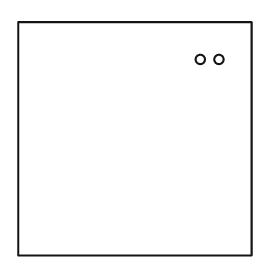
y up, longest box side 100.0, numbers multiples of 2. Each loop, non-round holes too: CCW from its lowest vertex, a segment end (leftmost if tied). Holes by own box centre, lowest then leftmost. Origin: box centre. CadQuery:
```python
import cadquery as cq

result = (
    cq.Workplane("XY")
    .moveTo(-50.0, -50.0)
    .lineTo(50.0, -50.0)
    .lineTo(50.0, 50.0)
    .lineTo(-50.0, 50.0)
    .close()
    .moveTo(28.0, 34.0)
    .circle(2.0)
    .moveTo(36.0, 34.0)
    .circle(2.0)
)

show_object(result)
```